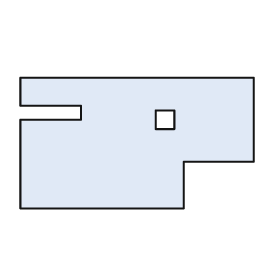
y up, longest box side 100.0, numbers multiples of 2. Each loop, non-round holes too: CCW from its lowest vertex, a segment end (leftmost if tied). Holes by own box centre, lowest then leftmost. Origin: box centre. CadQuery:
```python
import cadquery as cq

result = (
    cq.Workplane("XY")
    .moveTo(-50.0, -28.0)
    .lineTo(20.0, -28.0)
    .lineTo(20.0, -8.0)
    .lineTo(50.0, -8.0)
    .lineTo(50.0, 28.0)
    .lineTo(-50.0, 28.0)
    .lineTo(-50.0, 16.0)
    .lineTo(-24.0, 16.0)
    .lineTo(-24.0, 10.0)
    .lineTo(-50.0, 10.0)
    .close()
    .moveTo(8.0, 6.0)
    .lineTo(16.0, 6.0)
    .lineTo(16.0, 14.0)
    .lineTo(8.0, 14.0)
    .close()
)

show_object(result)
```